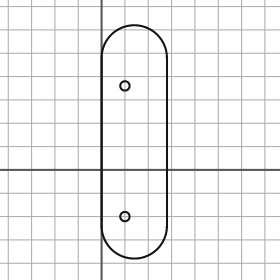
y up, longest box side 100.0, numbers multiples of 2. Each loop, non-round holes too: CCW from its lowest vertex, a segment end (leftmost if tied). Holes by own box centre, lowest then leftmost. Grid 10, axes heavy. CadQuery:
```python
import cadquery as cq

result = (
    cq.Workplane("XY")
    .moveTo(0.0, -24.0)
    .threePointArc((14.0, -38.0), (28.0, -24.0))
    .lineTo(28.0, 48.0)
    .threePointArc((14.0, 62.0), (0.0, 48.0))
    .close()
    .moveTo(10.0, -20.0)
    .circle(2.0)
    .moveTo(10.0, 36.0)
    .circle(2.0)
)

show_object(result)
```